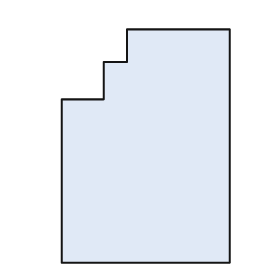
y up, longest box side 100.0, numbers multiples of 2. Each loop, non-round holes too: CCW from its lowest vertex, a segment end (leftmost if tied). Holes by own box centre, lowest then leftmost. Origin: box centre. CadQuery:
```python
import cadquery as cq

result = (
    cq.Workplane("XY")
    .moveTo(-36.0, -50.0)
    .lineTo(36.0, -50.0)
    .lineTo(36.0, 50.0)
    .lineTo(-8.0, 50.0)
    .lineTo(-8.0, 36.0)
    .lineTo(-18.0, 36.0)
    .lineTo(-18.0, 20.0)
    .lineTo(-36.0, 20.0)
    .close()
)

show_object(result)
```